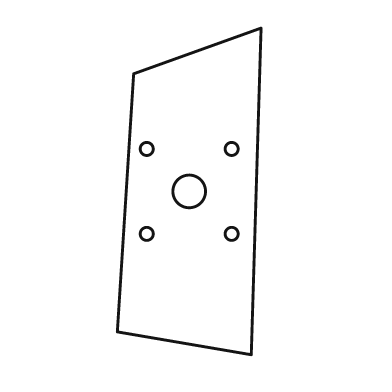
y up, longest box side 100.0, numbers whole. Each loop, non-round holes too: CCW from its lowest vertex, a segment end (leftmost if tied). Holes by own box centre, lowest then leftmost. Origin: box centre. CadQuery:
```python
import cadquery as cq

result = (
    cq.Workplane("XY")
    .moveTo(19.0, -50.0)
    .lineTo(22.0, 50.0)
    .lineTo(-17.0, 36.0)
    .lineTo(-22.0, -43.0)
    .close()
    .moveTo(-13.0, -13.0)
    .circle(2.0)
    .moveTo(13.0, -13.0)
    .circle(2.0)
    .moveTo(0.0, 0.0)
    .circle(5.0)
    .moveTo(-13.0, 13.0)
    .circle(2.0)
    .moveTo(13.0, 13.0)
    .circle(2.0)
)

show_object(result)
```